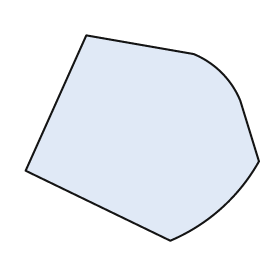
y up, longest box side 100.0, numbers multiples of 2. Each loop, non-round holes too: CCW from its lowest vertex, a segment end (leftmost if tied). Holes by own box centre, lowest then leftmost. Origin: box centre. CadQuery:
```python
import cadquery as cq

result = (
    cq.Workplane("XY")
    .moveTo(12.0, -44.0)
    .threePointArc((34.0, -30.0), (50.0, -10.0))
    .lineTo(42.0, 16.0)
    .threePointArc((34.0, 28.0), (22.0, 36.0))
    .lineTo(-24.0, 44.0)
    .lineTo(-50.0, -14.0)
    .close()
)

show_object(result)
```